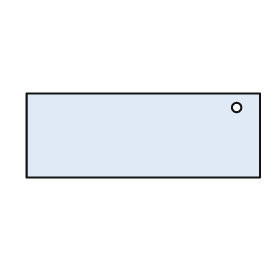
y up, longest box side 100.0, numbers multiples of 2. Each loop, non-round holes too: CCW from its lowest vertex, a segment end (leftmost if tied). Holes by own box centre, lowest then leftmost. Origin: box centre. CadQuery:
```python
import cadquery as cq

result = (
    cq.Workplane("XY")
    .moveTo(-50.0, -18.0)
    .lineTo(50.0, -18.0)
    .lineTo(50.0, 18.0)
    .lineTo(-50.0, 18.0)
    .close()
    .moveTo(40.0, 12.0)
    .circle(2.0)
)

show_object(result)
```